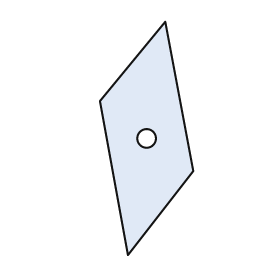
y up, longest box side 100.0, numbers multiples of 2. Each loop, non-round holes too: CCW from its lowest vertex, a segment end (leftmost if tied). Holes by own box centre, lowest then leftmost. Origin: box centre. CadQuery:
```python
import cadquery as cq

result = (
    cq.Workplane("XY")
    .moveTo(-8.0, -50.0)
    .lineTo(20.0, -14.0)
    .lineTo(8.0, 50.0)
    .lineTo(-20.0, 16.0)
    .close()
    .moveTo(0.0, 0.0)
    .circle(4.0)
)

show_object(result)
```